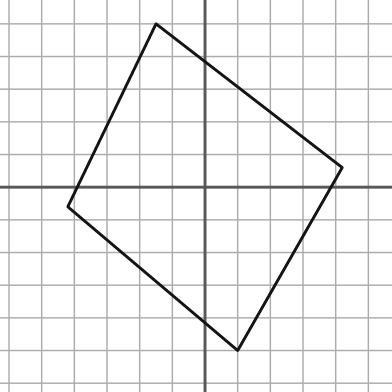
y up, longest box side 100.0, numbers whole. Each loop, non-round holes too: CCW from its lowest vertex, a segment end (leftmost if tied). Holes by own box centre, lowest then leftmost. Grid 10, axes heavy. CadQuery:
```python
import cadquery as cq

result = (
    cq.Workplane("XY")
    .moveTo(10.0, -50.0)
    .lineTo(42.0, 6.0)
    .lineTo(-15.0, 50.0)
    .lineTo(-42.0, -6.0)
    .close()
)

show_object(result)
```